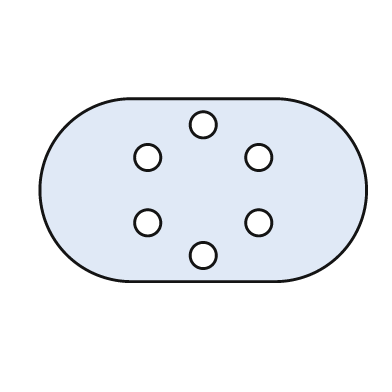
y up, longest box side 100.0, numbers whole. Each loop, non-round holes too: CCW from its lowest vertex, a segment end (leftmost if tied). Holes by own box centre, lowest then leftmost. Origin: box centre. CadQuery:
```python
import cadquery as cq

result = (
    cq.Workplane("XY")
    .moveTo(-22.0, -28.0)
    .lineTo(22.0, -28.0)
    .threePointArc((50.0, 0.0), (22.0, 28.0))
    .lineTo(-22.0, 28.0)
    .threePointArc((-50.0, 0.0), (-22.0, -28.0))
    .close()
    .moveTo(0.0, -20.0)
    .circle(4.0)
    .moveTo(-17.0, -10.0)
    .circle(4.0)
    .moveTo(17.0, -10.0)
    .circle(4.0)
    .moveTo(-17.0, 10.0)
    .circle(4.0)
    .moveTo(17.0, 10.0)
    .circle(4.0)
    .moveTo(0.0, 20.0)
    .circle(4.0)
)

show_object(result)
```